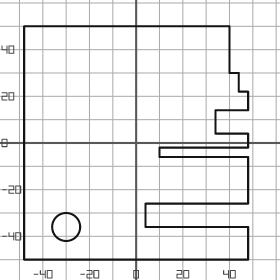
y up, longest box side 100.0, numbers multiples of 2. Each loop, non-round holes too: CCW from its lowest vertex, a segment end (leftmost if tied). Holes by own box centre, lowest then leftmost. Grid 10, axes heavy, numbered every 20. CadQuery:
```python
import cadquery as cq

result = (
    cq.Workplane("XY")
    .moveTo(-48.0, -50.0)
    .lineTo(48.0, -50.0)
    .lineTo(48.0, -36.0)
    .lineTo(4.0, -36.0)
    .lineTo(4.0, -26.0)
    .lineTo(48.0, -26.0)
    .lineTo(48.0, -6.0)
    .lineTo(10.0, -6.0)
    .lineTo(10.0, -2.0)
    .lineTo(48.0, -2.0)
    .lineTo(48.0, 4.0)
    .lineTo(34.0, 4.0)
    .lineTo(34.0, 14.0)
    .lineTo(48.0, 14.0)
    .lineTo(48.0, 22.0)
    .lineTo(44.0, 22.0)
    .lineTo(44.0, 30.0)
    .lineTo(40.0, 30.0)
    .lineTo(40.0, 50.0)
    .lineTo(-48.0, 50.0)
    .close()
    .moveTo(-30.0, -36.0)
    .circle(6.0)
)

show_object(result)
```